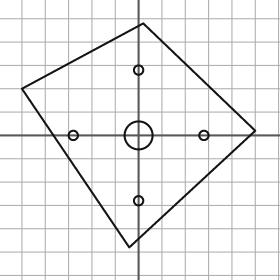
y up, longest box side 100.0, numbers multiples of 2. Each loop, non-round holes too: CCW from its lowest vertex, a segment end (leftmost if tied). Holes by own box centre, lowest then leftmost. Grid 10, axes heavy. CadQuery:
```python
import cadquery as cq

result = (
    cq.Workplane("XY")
    .moveTo(-4.0, -48.0)
    .lineTo(50.0, 2.0)
    .lineTo(2.0, 48.0)
    .lineTo(-50.0, 20.0)
    .close()
    .moveTo(0.0, -28.0)
    .circle(2.0)
    .moveTo(-28.0, 0.0)
    .circle(2.0)
    .moveTo(0.0, 0.0)
    .circle(6.0)
    .moveTo(28.0, 0.0)
    .circle(2.0)
    .moveTo(0.0, 28.0)
    .circle(2.0)
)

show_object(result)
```